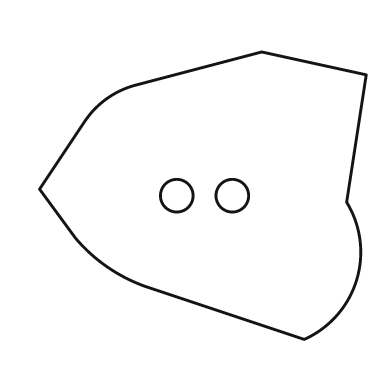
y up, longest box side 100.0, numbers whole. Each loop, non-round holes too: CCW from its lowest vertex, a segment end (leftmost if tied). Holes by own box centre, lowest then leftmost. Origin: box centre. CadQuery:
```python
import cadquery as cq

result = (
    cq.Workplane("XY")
    .moveTo(31.0, -44.0)
    .threePointArc((47.0, -26.0), (44.0, -2.0))
    .lineTo(50.0, 37.0)
    .lineTo(18.0, 44.0)
    .lineTo(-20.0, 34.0)
    .threePointArc((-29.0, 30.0), (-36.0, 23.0))
    .lineTo(-50.0, 2.0)
    .lineTo(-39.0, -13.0)
    .threePointArc((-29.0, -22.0), (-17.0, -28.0))
    .close()
    .moveTo(-8.0, 0.0)
    .circle(5.0)
    .moveTo(9.0, 0.0)
    .circle(5.0)
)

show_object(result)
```